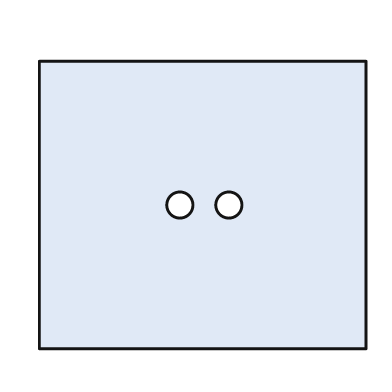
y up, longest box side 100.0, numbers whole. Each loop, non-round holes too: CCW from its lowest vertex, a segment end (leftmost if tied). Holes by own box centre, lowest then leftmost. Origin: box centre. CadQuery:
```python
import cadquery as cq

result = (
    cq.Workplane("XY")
    .moveTo(-50.0, -44.0)
    .lineTo(50.0, -44.0)
    .lineTo(50.0, 44.0)
    .lineTo(-50.0, 44.0)
    .close()
    .moveTo(-7.0, 0.0)
    .circle(4.0)
    .moveTo(8.0, 0.0)
    .circle(4.0)
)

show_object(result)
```